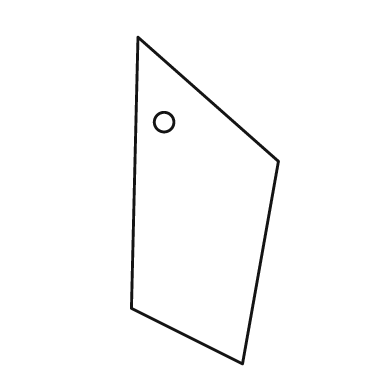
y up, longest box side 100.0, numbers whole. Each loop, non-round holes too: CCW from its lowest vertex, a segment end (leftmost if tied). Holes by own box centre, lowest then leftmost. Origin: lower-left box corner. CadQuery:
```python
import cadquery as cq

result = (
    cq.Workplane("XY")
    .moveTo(34.0, 0.0)
    .lineTo(45.0, 62.0)
    .lineTo(2.0, 100.0)
    .lineTo(0.0, 17.0)
    .close()
    .moveTo(10.0, 74.0)
    .circle(3.0)
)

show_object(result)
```